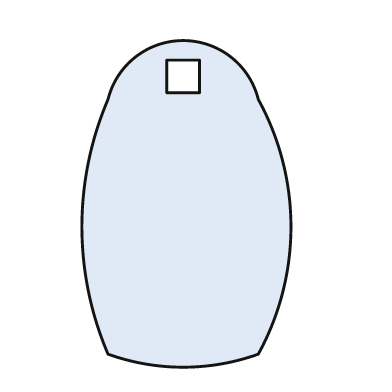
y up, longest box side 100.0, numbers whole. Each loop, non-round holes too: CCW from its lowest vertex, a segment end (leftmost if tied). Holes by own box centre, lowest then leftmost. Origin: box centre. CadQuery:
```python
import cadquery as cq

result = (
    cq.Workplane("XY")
    .moveTo(-24.0, -46.0)
    .threePointArc((-1.0, -50.0), (22.0, -46.0))
    .threePointArc((32.0, -7.0), (22.0, 32.0))
    .threePointArc((-1.0, 50.0), (-24.0, 32.0))
    .threePointArc((-32.0, -7.0), (-24.0, -46.0))
    .close()
    .moveTo(-6.0, 34.0)
    .lineTo(4.0, 34.0)
    .lineTo(4.0, 44.0)
    .lineTo(-6.0, 44.0)
    .close()
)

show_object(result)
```